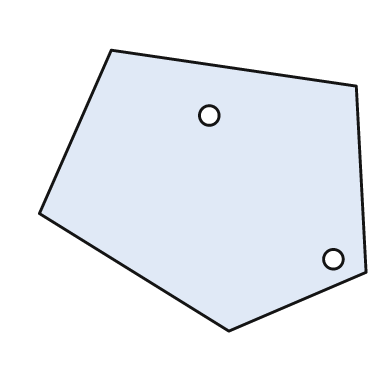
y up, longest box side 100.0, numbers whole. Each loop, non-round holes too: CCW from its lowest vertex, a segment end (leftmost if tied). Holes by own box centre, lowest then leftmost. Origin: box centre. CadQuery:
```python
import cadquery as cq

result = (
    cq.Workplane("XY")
    .moveTo(8.0, -43.0)
    .lineTo(50.0, -25.0)
    .lineTo(47.0, 32.0)
    .lineTo(-28.0, 43.0)
    .lineTo(-50.0, -7.0)
    .close()
    .moveTo(40.0, -21.0)
    .circle(3.0)
    .moveTo(2.0, 23.0)
    .circle(3.0)
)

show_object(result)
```